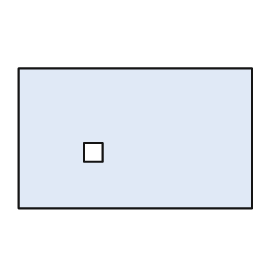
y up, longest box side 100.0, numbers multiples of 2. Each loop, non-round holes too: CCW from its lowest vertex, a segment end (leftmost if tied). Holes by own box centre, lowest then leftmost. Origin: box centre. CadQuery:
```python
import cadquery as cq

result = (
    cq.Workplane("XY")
    .moveTo(-50.0, -30.0)
    .lineTo(50.0, -30.0)
    .lineTo(50.0, 30.0)
    .lineTo(-50.0, 30.0)
    .close()
    .moveTo(-22.0, -10.0)
    .lineTo(-14.0, -10.0)
    .lineTo(-14.0, -2.0)
    .lineTo(-22.0, -2.0)
    .close()
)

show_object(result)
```